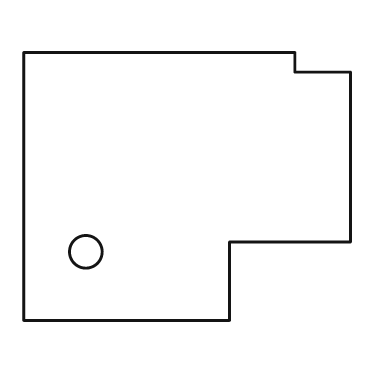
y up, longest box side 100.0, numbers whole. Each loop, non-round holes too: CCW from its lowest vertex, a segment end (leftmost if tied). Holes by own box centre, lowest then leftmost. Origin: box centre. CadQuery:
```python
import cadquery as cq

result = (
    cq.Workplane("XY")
    .moveTo(-50.0, -41.0)
    .lineTo(13.0, -41.0)
    .lineTo(13.0, -17.0)
    .lineTo(50.0, -17.0)
    .lineTo(50.0, 35.0)
    .lineTo(33.0, 35.0)
    .lineTo(33.0, 41.0)
    .lineTo(-50.0, 41.0)
    .close()
    .moveTo(-31.0, -20.0)
    .circle(5.0)
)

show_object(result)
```